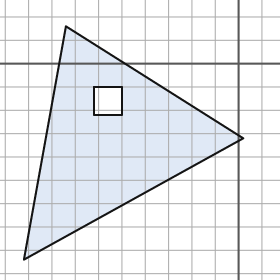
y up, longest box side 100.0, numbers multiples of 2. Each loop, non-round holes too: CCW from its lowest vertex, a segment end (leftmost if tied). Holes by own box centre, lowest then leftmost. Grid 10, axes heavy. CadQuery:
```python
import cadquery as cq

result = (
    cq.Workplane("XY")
    .moveTo(-92.0, -84.0)
    .lineTo(2.0, -32.0)
    .lineTo(-74.0, 16.0)
    .close()
    .moveTo(-62.0, -22.0)
    .lineTo(-50.0, -22.0)
    .lineTo(-50.0, -10.0)
    .lineTo(-62.0, -10.0)
    .close()
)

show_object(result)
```